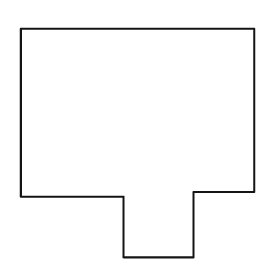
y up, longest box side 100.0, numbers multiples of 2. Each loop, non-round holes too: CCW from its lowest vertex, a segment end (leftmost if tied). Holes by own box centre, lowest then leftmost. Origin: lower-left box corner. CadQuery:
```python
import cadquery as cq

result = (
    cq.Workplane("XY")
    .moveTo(44.0, 0.0)
    .lineTo(74.0, 0.0)
    .lineTo(74.0, 28.0)
    .lineTo(100.0, 28.0)
    .lineTo(100.0, 98.0)
    .lineTo(0.0, 98.0)
    .lineTo(0.0, 26.0)
    .lineTo(44.0, 26.0)
    .close()
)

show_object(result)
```